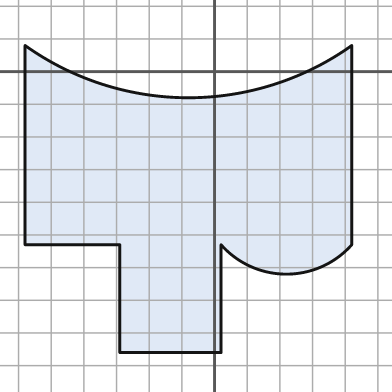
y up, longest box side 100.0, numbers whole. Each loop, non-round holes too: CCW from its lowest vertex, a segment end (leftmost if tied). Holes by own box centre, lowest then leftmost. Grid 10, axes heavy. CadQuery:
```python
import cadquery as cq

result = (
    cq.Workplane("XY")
    .moveTo(-29.0, -86.0)
    .lineTo(2.0, -86.0)
    .lineTo(2.0, -53.0)
    .threePointArc((22.0, -62.0), (42.0, -53.0))
    .lineTo(42.0, 8.0)
    .threePointArc((-8.0, -8.0), (-58.0, 8.0))
    .lineTo(-58.0, -53.0)
    .lineTo(-29.0, -53.0)
    .close()
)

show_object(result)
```